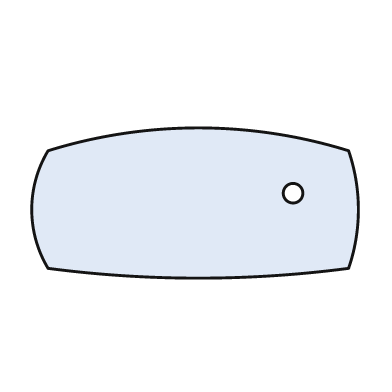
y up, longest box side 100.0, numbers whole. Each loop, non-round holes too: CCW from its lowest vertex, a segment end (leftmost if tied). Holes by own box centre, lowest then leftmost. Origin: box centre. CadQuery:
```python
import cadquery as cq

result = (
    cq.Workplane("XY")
    .moveTo(-45.0, -20.0)
    .threePointArc((1.0, -23.0), (47.0, -20.0))
    .threePointArc((50.0, -2.0), (47.0, 16.0))
    .threePointArc((1.0, 23.0), (-45.0, 16.0))
    .threePointArc((-50.0, -2.0), (-45.0, -20.0))
    .close()
    .moveTo(30.0, 3.0)
    .circle(3.0)
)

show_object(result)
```